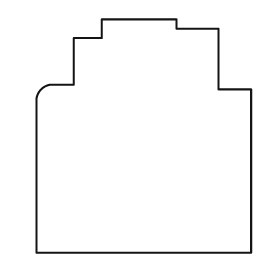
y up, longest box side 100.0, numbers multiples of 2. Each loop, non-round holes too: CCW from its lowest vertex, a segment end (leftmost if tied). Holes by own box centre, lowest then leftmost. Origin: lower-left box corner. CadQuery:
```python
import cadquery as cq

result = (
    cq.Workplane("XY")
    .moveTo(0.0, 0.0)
    .lineTo(92.0, 0.0)
    .lineTo(92.0, 70.0)
    .lineTo(78.0, 70.0)
    .lineTo(78.0, 96.0)
    .lineTo(60.0, 96.0)
    .lineTo(60.0, 100.0)
    .lineTo(28.0, 100.0)
    .lineTo(28.0, 92.0)
    .lineTo(16.0, 92.0)
    .lineTo(16.0, 72.0)
    .lineTo(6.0, 72.0)
    .threePointArc((2.0, 70.0), (0.0, 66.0))
    .close()
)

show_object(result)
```